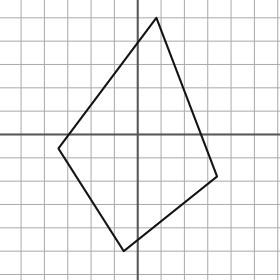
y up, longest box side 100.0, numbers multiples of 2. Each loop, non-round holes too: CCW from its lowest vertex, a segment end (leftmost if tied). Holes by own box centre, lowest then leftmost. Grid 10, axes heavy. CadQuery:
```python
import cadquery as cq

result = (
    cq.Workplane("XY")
    .moveTo(-6.0, -50.0)
    .lineTo(34.0, -18.0)
    .lineTo(8.0, 50.0)
    .lineTo(-34.0, -6.0)
    .close()
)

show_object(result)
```